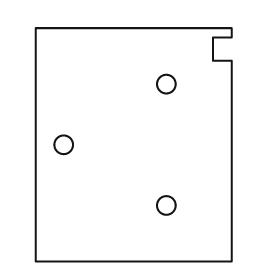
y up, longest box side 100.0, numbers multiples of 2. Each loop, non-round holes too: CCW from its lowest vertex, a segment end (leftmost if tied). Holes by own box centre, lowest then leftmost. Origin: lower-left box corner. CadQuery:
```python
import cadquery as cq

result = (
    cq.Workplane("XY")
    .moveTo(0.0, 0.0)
    .lineTo(84.0, 0.0)
    .lineTo(84.0, 86.0)
    .lineTo(76.0, 86.0)
    .lineTo(76.0, 96.0)
    .lineTo(84.0, 96.0)
    .lineTo(84.0, 100.0)
    .lineTo(0.0, 100.0)
    .close()
    .moveTo(56.0, 24.0)
    .circle(4.0)
    .moveTo(12.0, 50.0)
    .circle(4.0)
    .moveTo(56.0, 76.0)
    .circle(4.0)
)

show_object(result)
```